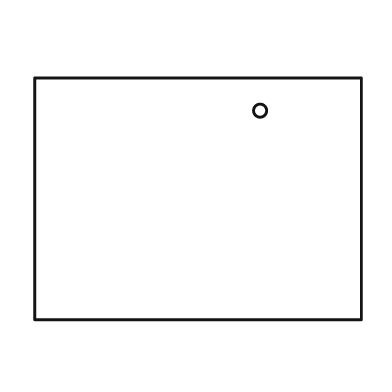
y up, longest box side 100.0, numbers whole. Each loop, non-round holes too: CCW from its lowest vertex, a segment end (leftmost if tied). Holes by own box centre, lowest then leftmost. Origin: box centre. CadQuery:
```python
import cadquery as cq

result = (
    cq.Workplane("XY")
    .moveTo(-50.0, -37.0)
    .lineTo(50.0, -37.0)
    .lineTo(50.0, 37.0)
    .lineTo(-50.0, 37.0)
    .close()
    .moveTo(19.0, 27.0)
    .circle(2.0)
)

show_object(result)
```